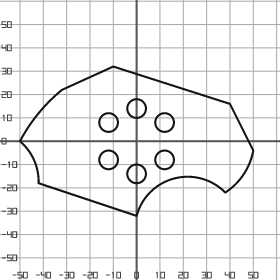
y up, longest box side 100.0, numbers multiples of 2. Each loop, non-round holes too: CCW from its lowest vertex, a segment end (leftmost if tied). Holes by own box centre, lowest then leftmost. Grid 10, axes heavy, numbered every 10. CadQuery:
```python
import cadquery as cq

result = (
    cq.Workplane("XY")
    .moveTo(0.0, -32.0)
    .threePointArc((16.0, -16.0), (38.0, -22.0))
    .threePointArc((46.0, -14.0), (50.0, -4.0))
    .lineTo(40.0, 16.0)
    .lineTo(-10.0, 32.0)
    .lineTo(-32.0, 22.0)
    .threePointArc((-42.0, 12.0), (-50.0, 0.0))
    .threePointArc((-44.0, -8.0), (-42.0, -18.0))
    .close()
    .moveTo(0.0, -14.0)
    .circle(4.0)
    .moveTo(-12.0, -8.0)
    .circle(4.0)
    .moveTo(12.0, -8.0)
    .circle(4.0)
    .moveTo(-12.0, 8.0)
    .circle(4.0)
    .moveTo(12.0, 8.0)
    .circle(4.0)
    .moveTo(0.0, 14.0)
    .circle(4.0)
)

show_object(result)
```